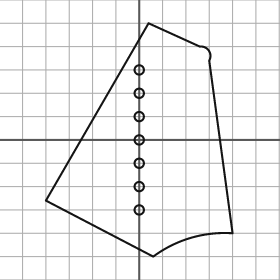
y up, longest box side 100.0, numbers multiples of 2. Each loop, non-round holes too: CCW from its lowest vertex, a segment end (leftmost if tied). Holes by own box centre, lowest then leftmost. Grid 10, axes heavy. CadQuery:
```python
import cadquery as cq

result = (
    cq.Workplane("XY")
    .moveTo(6.0, -50.0)
    .threePointArc((22.0, -42.0), (40.0, -40.0))
    .lineTo(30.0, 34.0)
    .threePointArc((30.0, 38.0), (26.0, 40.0))
    .lineTo(4.0, 50.0)
    .lineTo(-40.0, -26.0)
    .close()
    .moveTo(0.0, -30.0)
    .circle(2.0)
    .moveTo(0.0, -20.0)
    .circle(2.0)
    .moveTo(0.0, -10.0)
    .circle(2.0)
    .moveTo(0.0, 0.0)
    .circle(2.0)
    .moveTo(0.0, 10.0)
    .circle(2.0)
    .moveTo(0.0, 20.0)
    .circle(2.0)
    .moveTo(0.0, 30.0)
    .circle(2.0)
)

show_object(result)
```